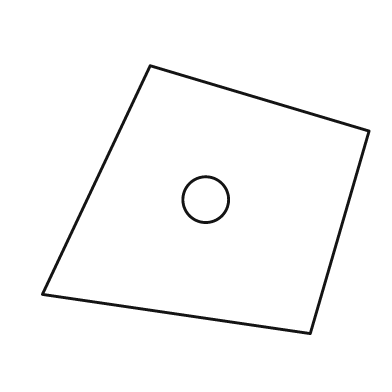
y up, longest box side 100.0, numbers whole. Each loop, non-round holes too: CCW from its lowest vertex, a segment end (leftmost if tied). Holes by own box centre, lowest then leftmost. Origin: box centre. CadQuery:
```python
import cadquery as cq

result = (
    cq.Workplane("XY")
    .moveTo(32.0, -41.0)
    .lineTo(50.0, 21.0)
    .lineTo(-17.0, 41.0)
    .lineTo(-50.0, -29.0)
    .close()
    .moveTo(0.0, 0.0)
    .circle(7.0)
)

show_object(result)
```